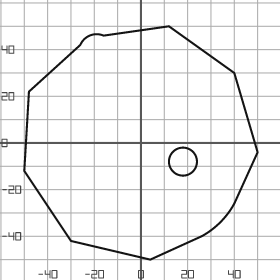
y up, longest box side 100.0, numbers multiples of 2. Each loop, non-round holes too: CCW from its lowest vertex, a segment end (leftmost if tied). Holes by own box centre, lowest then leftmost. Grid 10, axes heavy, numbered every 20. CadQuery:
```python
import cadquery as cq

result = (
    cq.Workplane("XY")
    .moveTo(4.0, -50.0)
    .lineTo(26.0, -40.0)
    .threePointArc((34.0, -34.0), (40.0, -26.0))
    .lineTo(50.0, -4.0)
    .lineTo(40.0, 30.0)
    .lineTo(12.0, 50.0)
    .lineTo(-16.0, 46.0)
    .threePointArc((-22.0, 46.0), (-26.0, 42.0))
    .lineTo(-48.0, 22.0)
    .lineTo(-50.0, -12.0)
    .lineTo(-30.0, -42.0)
    .close()
    .moveTo(18.0, -8.0)
    .circle(6.0)
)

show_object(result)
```